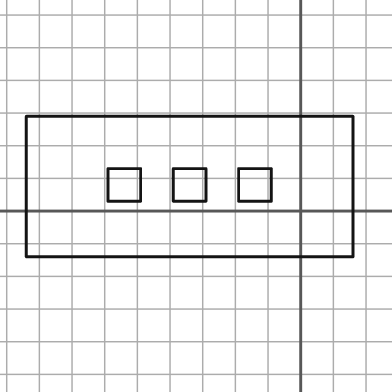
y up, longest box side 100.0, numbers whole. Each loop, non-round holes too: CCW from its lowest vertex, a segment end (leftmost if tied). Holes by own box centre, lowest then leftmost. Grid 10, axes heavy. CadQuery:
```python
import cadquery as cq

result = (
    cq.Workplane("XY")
    .moveTo(-84.0, -14.0)
    .lineTo(16.0, -14.0)
    .lineTo(16.0, 29.0)
    .lineTo(-84.0, 29.0)
    .close()
    .moveTo(-59.0, 3.0)
    .lineTo(-49.0, 3.0)
    .lineTo(-49.0, 13.0)
    .lineTo(-59.0, 13.0)
    .close()
    .moveTo(-39.0, 3.0)
    .lineTo(-29.0, 3.0)
    .lineTo(-29.0, 13.0)
    .lineTo(-39.0, 13.0)
    .close()
    .moveTo(-19.0, 3.0)
    .lineTo(-9.0, 3.0)
    .lineTo(-9.0, 13.0)
    .lineTo(-19.0, 13.0)
    .close()
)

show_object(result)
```